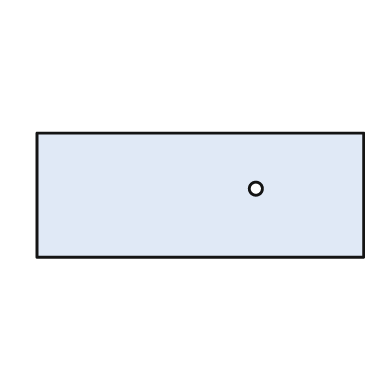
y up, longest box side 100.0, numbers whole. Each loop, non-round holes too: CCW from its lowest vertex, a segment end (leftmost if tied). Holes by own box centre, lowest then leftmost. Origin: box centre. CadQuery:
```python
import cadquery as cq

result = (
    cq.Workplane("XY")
    .moveTo(-50.0, -19.0)
    .lineTo(50.0, -19.0)
    .lineTo(50.0, 19.0)
    .lineTo(-50.0, 19.0)
    .close()
    .moveTo(17.0, 2.0)
    .circle(2.0)
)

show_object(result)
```